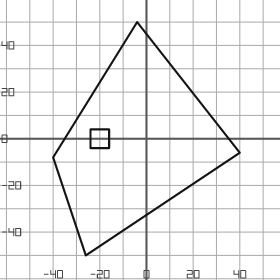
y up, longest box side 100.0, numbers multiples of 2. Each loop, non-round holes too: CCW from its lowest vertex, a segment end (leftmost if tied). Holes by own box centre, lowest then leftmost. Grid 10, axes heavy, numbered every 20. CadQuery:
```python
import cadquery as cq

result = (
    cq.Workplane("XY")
    .moveTo(-26.0, -50.0)
    .lineTo(40.0, -6.0)
    .lineTo(-4.0, 50.0)
    .lineTo(-40.0, -8.0)
    .close()
    .moveTo(-24.0, -4.0)
    .lineTo(-16.0, -4.0)
    .lineTo(-16.0, 4.0)
    .lineTo(-24.0, 4.0)
    .close()
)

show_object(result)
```